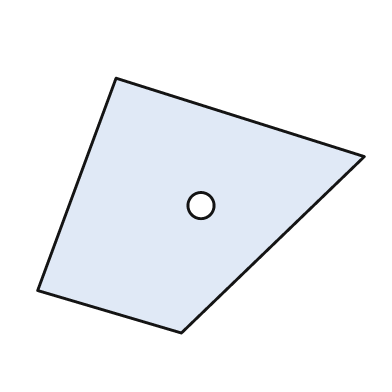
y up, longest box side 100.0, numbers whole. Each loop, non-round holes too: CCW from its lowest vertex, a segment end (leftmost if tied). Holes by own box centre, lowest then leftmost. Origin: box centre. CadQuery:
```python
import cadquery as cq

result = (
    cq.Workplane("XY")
    .moveTo(-6.0, -39.0)
    .lineTo(50.0, 15.0)
    .lineTo(-26.0, 39.0)
    .lineTo(-50.0, -26.0)
    .close()
    .moveTo(0.0, 0.0)
    .circle(4.0)
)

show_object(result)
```